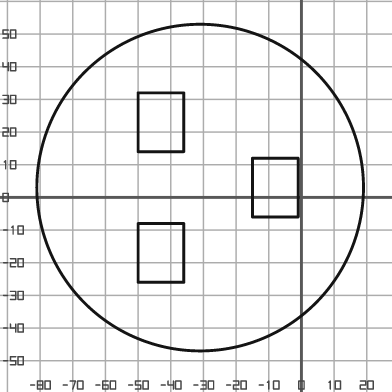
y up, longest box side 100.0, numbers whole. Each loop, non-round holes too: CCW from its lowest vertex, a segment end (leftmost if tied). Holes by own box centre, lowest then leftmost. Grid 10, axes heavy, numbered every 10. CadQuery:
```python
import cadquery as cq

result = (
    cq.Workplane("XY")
    .moveTo(-31.0, 3.0)
    .circle(50.0)
    .moveTo(-50.0, -26.0)
    .lineTo(-36.0, -26.0)
    .lineTo(-36.0, -8.0)
    .lineTo(-50.0, -8.0)
    .close()
    .moveTo(-15.0, -6.0)
    .lineTo(-1.0, -6.0)
    .lineTo(-1.0, 12.0)
    .lineTo(-15.0, 12.0)
    .close()
    .moveTo(-50.0, 14.0)
    .lineTo(-36.0, 14.0)
    .lineTo(-36.0, 32.0)
    .lineTo(-50.0, 32.0)
    .close()
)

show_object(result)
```